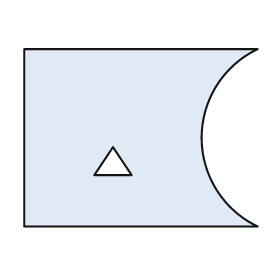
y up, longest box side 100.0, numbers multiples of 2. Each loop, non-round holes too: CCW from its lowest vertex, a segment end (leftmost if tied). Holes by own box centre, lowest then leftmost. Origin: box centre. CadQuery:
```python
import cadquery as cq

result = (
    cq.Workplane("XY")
    .moveTo(-50.0, -38.0)
    .lineTo(50.0, -38.0)
    .threePointArc((26.0, 0.0), (50.0, 38.0))
    .lineTo(-50.0, 38.0)
    .close()
    .moveTo(-20.0, -16.0)
    .lineTo(-4.0, -16.0)
    .lineTo(-12.0, -4.0)
    .close()
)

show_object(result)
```